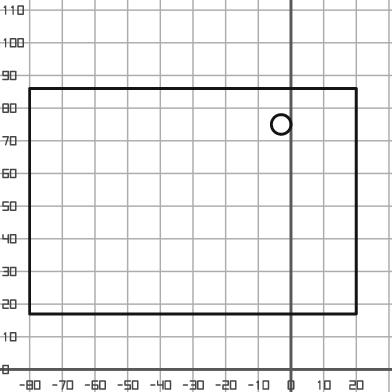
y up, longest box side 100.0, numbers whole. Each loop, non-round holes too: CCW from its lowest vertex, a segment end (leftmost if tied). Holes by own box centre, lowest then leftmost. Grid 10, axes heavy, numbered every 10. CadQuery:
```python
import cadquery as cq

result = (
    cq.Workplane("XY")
    .moveTo(-80.0, 17.0)
    .lineTo(20.0, 17.0)
    .lineTo(20.0, 86.0)
    .lineTo(-80.0, 86.0)
    .close()
    .moveTo(-3.0, 75.0)
    .circle(3.0)
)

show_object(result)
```